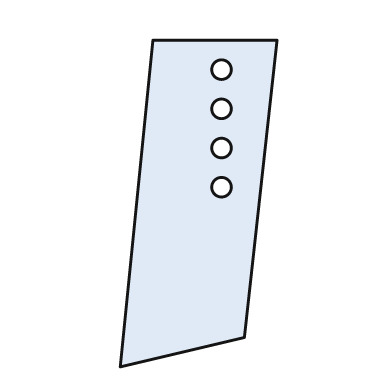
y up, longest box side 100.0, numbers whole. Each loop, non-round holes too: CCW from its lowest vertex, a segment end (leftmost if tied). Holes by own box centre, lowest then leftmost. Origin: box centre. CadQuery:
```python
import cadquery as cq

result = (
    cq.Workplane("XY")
    .moveTo(-24.0, -50.0)
    .lineTo(14.0, -41.0)
    .lineTo(24.0, 50.0)
    .lineTo(-14.0, 50.0)
    .close()
    .moveTo(7.0, 5.0)
    .circle(3.0)
    .moveTo(7.0, 17.0)
    .circle(3.0)
    .moveTo(7.0, 29.0)
    .circle(3.0)
    .moveTo(7.0, 41.0)
    .circle(3.0)
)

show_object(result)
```